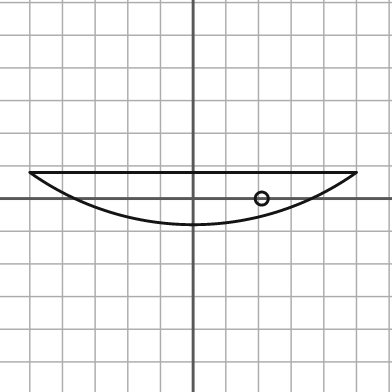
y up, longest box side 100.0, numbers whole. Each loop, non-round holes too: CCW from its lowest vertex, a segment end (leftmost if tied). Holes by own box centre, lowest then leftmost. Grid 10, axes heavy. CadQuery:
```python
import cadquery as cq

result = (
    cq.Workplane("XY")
    .moveTo(-50.0, 8.0)
    .threePointArc((0.0, -8.0), (50.0, 8.0))
    .close()
    .moveTo(21.0, 0.0)
    .circle(2.0)
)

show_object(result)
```